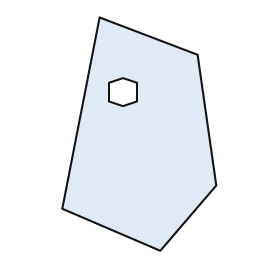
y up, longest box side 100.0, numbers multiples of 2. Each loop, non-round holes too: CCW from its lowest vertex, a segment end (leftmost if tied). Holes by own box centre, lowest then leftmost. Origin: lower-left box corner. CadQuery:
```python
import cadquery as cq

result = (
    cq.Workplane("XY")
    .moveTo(42.0, 0.0)
    .lineTo(66.0, 28.0)
    .lineTo(58.0, 84.0)
    .lineTo(16.0, 100.0)
    .lineTo(0.0, 18.0)
    .close()
    .moveTo(26.0, 62.0)
    .lineTo(32.0, 64.0)
    .lineTo(32.0, 72.0)
    .lineTo(26.0, 74.0)
    .lineTo(20.0, 72.0)
    .lineTo(20.0, 64.0)
    .close()
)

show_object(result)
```